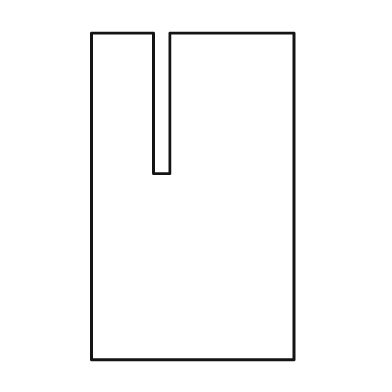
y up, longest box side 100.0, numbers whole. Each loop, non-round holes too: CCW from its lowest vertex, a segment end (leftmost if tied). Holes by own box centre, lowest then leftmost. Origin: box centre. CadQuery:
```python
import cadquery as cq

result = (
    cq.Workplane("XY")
    .moveTo(-31.0, -50.0)
    .lineTo(31.0, -50.0)
    .lineTo(31.0, 50.0)
    .lineTo(-7.0, 50.0)
    .lineTo(-7.0, 7.0)
    .lineTo(-12.0, 7.0)
    .lineTo(-12.0, 50.0)
    .lineTo(-31.0, 50.0)
    .close()
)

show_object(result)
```